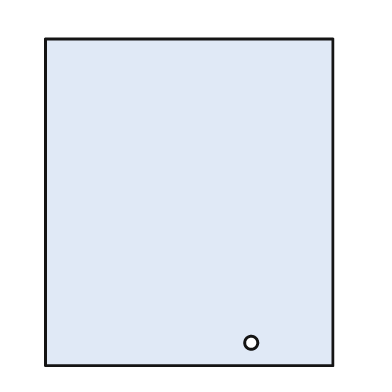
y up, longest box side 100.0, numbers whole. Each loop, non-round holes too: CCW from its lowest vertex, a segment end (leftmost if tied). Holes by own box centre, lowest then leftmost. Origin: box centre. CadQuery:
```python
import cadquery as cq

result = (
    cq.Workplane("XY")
    .moveTo(-44.0, -50.0)
    .lineTo(44.0, -50.0)
    .lineTo(44.0, 50.0)
    .lineTo(-44.0, 50.0)
    .close()
    .moveTo(19.0, -43.0)
    .circle(2.0)
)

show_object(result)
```